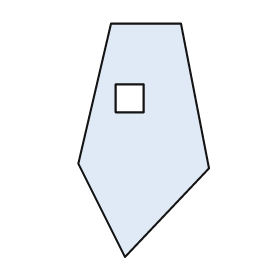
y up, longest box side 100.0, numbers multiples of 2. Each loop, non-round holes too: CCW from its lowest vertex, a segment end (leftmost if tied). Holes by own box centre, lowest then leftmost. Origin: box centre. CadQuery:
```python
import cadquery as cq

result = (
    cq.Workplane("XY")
    .moveTo(-8.0, -50.0)
    .lineTo(28.0, -12.0)
    .lineTo(16.0, 50.0)
    .lineTo(-14.0, 50.0)
    .lineTo(-28.0, -10.0)
    .close()
    .moveTo(-12.0, 12.0)
    .lineTo(0.0, 12.0)
    .lineTo(0.0, 24.0)
    .lineTo(-12.0, 24.0)
    .close()
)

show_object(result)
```